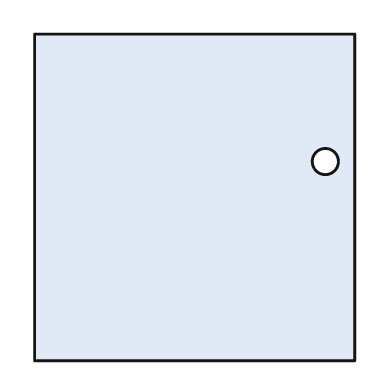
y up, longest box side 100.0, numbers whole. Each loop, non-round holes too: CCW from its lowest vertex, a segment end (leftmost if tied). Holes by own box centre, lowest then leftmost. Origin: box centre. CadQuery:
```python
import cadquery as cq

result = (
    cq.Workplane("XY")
    .moveTo(-49.0, -50.0)
    .lineTo(49.0, -50.0)
    .lineTo(49.0, 50.0)
    .lineTo(-49.0, 50.0)
    .close()
    .moveTo(40.0, 11.0)
    .circle(4.0)
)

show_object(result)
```